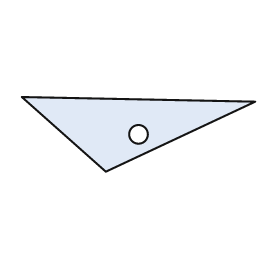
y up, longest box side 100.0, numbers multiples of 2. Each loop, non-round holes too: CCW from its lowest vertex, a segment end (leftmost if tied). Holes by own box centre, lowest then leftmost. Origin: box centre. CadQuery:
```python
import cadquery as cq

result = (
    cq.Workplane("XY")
    .moveTo(-14.0, -16.0)
    .lineTo(50.0, 14.0)
    .lineTo(-50.0, 16.0)
    .close()
    .moveTo(0.0, 0.0)
    .circle(4.0)
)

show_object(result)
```